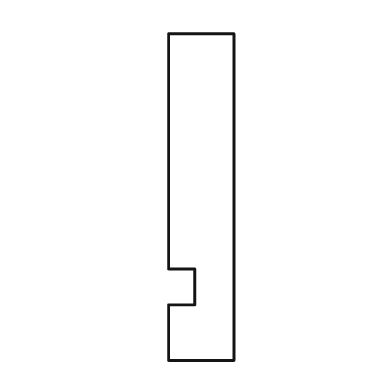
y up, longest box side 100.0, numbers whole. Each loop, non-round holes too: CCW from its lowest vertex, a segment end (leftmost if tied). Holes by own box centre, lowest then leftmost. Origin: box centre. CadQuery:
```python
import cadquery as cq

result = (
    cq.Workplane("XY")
    .moveTo(-10.0, -50.0)
    .lineTo(10.0, -50.0)
    .lineTo(10.0, 50.0)
    .lineTo(-10.0, 50.0)
    .lineTo(-10.0, -22.0)
    .lineTo(-2.0, -22.0)
    .lineTo(-2.0, -33.0)
    .lineTo(-10.0, -33.0)
    .close()
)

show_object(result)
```